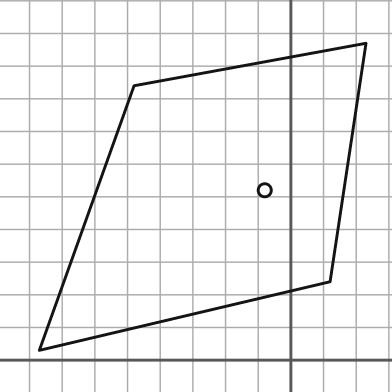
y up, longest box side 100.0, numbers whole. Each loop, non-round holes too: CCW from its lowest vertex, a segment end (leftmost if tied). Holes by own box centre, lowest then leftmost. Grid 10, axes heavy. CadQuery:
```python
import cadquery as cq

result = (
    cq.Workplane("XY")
    .moveTo(-77.0, 3.0)
    .lineTo(12.0, 24.0)
    .lineTo(23.0, 97.0)
    .lineTo(-48.0, 84.0)
    .close()
    .moveTo(-8.0, 52.0)
    .circle(2.0)
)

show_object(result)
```